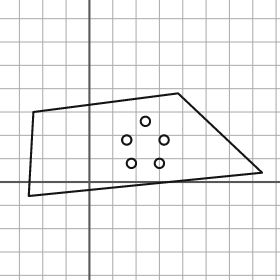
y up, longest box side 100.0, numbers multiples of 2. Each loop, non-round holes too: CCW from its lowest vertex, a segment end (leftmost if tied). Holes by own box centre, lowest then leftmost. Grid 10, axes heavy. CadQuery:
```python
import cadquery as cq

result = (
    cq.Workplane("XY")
    .moveTo(-26.0, -6.0)
    .lineTo(74.0, 4.0)
    .lineTo(38.0, 38.0)
    .lineTo(-24.0, 30.0)
    .close()
    .moveTo(18.0, 8.0)
    .circle(2.0)
    .moveTo(30.0, 8.0)
    .circle(2.0)
    .moveTo(16.0, 18.0)
    .circle(2.0)
    .moveTo(32.0, 18.0)
    .circle(2.0)
    .moveTo(24.0, 26.0)
    .circle(2.0)
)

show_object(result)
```